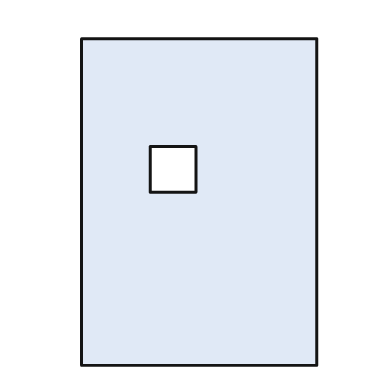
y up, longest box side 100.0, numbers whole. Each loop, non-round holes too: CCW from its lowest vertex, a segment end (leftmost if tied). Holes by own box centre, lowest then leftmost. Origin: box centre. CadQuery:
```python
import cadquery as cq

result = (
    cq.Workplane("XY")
    .moveTo(-36.0, -50.0)
    .lineTo(36.0, -50.0)
    .lineTo(36.0, 50.0)
    .lineTo(-36.0, 50.0)
    .close()
    .moveTo(-15.0, 3.0)
    .lineTo(-1.0, 3.0)
    .lineTo(-1.0, 17.0)
    .lineTo(-15.0, 17.0)
    .close()
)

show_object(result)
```